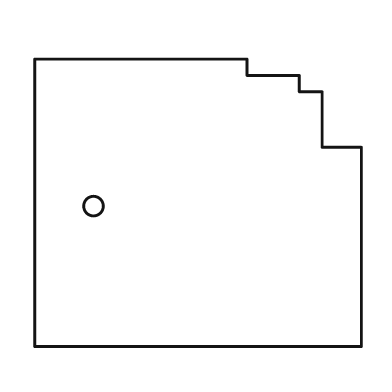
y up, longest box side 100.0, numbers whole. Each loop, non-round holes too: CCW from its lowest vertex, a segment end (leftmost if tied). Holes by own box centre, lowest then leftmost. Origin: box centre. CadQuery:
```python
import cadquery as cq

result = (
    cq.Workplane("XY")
    .moveTo(-50.0, -44.0)
    .lineTo(50.0, -44.0)
    .lineTo(50.0, 17.0)
    .lineTo(38.0, 17.0)
    .lineTo(38.0, 34.0)
    .lineTo(31.0, 34.0)
    .lineTo(31.0, 39.0)
    .lineTo(15.0, 39.0)
    .lineTo(15.0, 44.0)
    .lineTo(-50.0, 44.0)
    .close()
    .moveTo(-32.0, -1.0)
    .circle(3.0)
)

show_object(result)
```